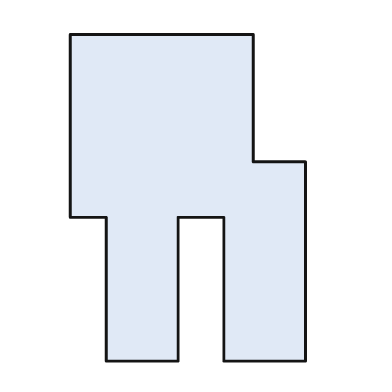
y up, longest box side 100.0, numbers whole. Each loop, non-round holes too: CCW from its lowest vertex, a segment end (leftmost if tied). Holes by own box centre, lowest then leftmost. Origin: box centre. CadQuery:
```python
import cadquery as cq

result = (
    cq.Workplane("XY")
    .moveTo(-25.0, -50.0)
    .lineTo(-3.0, -50.0)
    .lineTo(-3.0, -6.0)
    .lineTo(11.0, -6.0)
    .lineTo(11.0, -50.0)
    .lineTo(36.0, -50.0)
    .lineTo(36.0, 11.0)
    .lineTo(20.0, 11.0)
    .lineTo(20.0, 50.0)
    .lineTo(-36.0, 50.0)
    .lineTo(-36.0, -6.0)
    .lineTo(-25.0, -6.0)
    .close()
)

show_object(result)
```